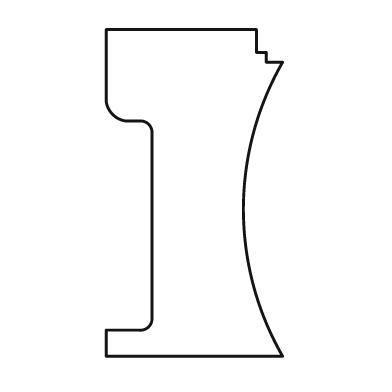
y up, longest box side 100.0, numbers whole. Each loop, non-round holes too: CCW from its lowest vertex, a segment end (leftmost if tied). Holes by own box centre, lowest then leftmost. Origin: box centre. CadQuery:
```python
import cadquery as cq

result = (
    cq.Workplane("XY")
    .moveTo(-27.0, -50.0)
    .lineTo(27.0, -50.0)
    .threePointArc((15.0, -5.0), (27.0, 40.0))
    .lineTo(22.0, 40.0)
    .lineTo(22.0, 43.0)
    .lineTo(19.0, 43.0)
    .lineTo(19.0, 50.0)
    .lineTo(-27.0, 50.0)
    .lineTo(-27.0, 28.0)
    .threePointArc((-25.0, 24.0), (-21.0, 22.0))
    .lineTo(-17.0, 22.0)
    .threePointArc((-14.0, 21.0), (-13.0, 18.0))
    .lineTo(-13.0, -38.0)
    .threePointArc((-14.0, -41.0), (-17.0, -42.0))
    .lineTo(-27.0, -42.0)
    .close()
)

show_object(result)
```